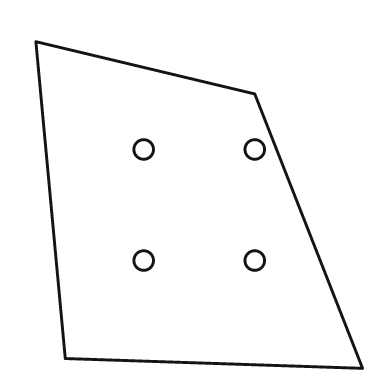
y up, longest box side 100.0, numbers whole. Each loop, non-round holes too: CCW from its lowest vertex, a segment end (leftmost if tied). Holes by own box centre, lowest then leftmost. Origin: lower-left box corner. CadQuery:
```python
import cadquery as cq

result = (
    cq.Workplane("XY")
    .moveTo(100.0, 0.0)
    .lineTo(67.0, 84.0)
    .lineTo(0.0, 100.0)
    .lineTo(9.0, 3.0)
    .close()
    .moveTo(33.0, 33.0)
    .circle(3.0)
    .moveTo(67.0, 33.0)
    .circle(3.0)
    .moveTo(33.0, 67.0)
    .circle(3.0)
    .moveTo(67.0, 67.0)
    .circle(3.0)
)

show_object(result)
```